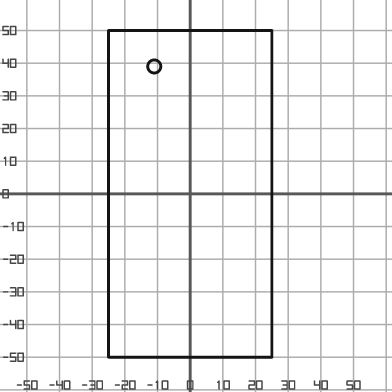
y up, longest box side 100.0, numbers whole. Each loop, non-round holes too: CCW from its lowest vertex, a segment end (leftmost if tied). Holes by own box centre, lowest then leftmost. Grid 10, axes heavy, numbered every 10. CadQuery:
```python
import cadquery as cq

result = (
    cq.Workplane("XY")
    .moveTo(-25.0, -50.0)
    .lineTo(25.0, -50.0)
    .lineTo(25.0, 50.0)
    .lineTo(-25.0, 50.0)
    .close()
    .moveTo(-11.0, 39.0)
    .circle(2.0)
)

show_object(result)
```